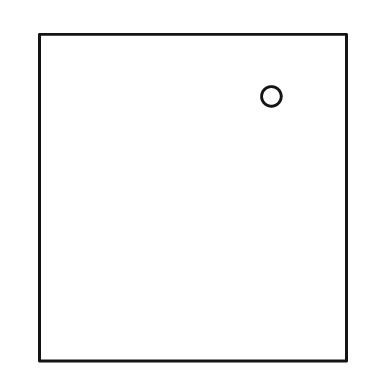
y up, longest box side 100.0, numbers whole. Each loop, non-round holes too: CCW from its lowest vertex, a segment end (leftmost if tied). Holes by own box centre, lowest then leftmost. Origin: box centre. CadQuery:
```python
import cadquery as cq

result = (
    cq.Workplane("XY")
    .moveTo(-47.0, -50.0)
    .lineTo(47.0, -50.0)
    .lineTo(47.0, 50.0)
    .lineTo(-47.0, 50.0)
    .close()
    .moveTo(24.0, 31.0)
    .circle(3.0)
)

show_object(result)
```